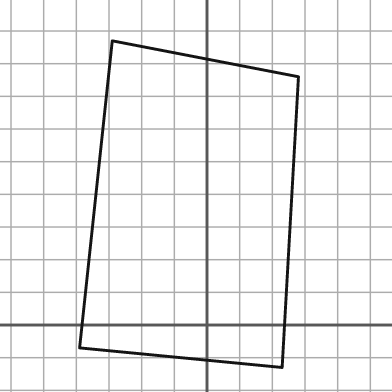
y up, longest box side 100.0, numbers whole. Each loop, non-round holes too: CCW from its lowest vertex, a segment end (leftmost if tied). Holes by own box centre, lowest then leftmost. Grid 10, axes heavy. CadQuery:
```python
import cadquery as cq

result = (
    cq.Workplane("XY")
    .moveTo(23.0, -13.0)
    .lineTo(28.0, 76.0)
    .lineTo(-29.0, 87.0)
    .lineTo(-39.0, -7.0)
    .close()
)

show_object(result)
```